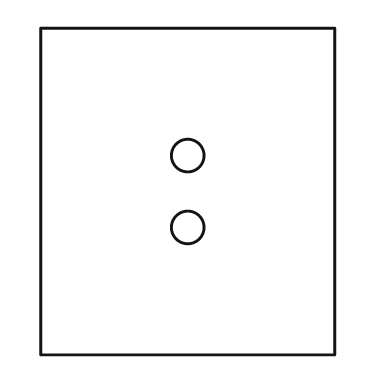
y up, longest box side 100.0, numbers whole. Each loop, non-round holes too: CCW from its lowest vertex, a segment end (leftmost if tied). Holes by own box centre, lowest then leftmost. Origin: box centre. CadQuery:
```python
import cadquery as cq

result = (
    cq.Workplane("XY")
    .moveTo(-45.0, -50.0)
    .lineTo(45.0, -50.0)
    .lineTo(45.0, 50.0)
    .lineTo(-45.0, 50.0)
    .close()
    .moveTo(0.0, -11.0)
    .circle(5.0)
    .moveTo(0.0, 11.0)
    .circle(5.0)
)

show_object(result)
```